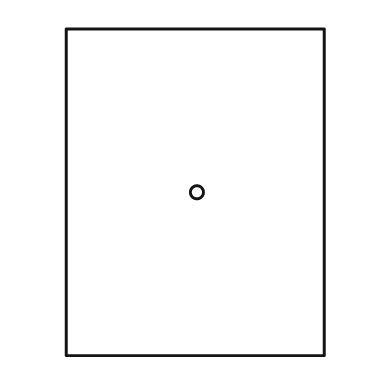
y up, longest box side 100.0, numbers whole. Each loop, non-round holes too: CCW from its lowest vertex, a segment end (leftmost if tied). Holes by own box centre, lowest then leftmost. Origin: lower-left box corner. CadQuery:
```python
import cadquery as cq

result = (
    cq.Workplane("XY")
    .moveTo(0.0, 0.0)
    .lineTo(79.0, 0.0)
    .lineTo(79.0, 100.0)
    .lineTo(0.0, 100.0)
    .close()
    .moveTo(40.0, 50.0)
    .circle(2.0)
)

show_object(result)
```